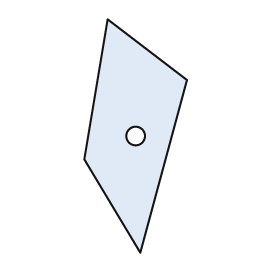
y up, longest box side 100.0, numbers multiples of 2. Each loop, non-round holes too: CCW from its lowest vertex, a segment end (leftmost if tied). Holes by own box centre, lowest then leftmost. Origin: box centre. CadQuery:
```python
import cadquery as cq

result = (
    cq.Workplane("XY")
    .moveTo(2.0, -50.0)
    .lineTo(22.0, 24.0)
    .lineTo(-12.0, 50.0)
    .lineTo(-22.0, -10.0)
    .close()
    .moveTo(0.0, 0.0)
    .circle(4.0)
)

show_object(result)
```